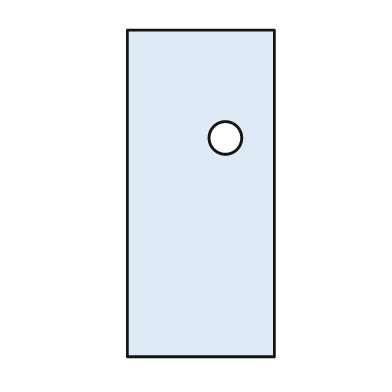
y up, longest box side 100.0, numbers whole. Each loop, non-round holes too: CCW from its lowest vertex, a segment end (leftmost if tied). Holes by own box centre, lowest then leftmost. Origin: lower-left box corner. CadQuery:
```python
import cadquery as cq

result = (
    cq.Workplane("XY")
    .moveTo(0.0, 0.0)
    .lineTo(45.0, 0.0)
    .lineTo(45.0, 100.0)
    .lineTo(0.0, 100.0)
    .close()
    .moveTo(30.0, 67.0)
    .circle(5.0)
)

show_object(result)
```